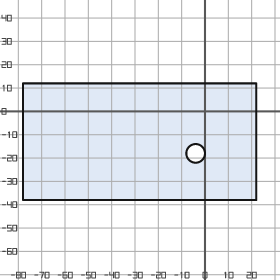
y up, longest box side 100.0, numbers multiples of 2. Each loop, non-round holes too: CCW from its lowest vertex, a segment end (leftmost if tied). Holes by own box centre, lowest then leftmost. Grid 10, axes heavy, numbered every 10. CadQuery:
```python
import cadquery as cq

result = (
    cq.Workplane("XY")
    .moveTo(-78.0, -38.0)
    .lineTo(22.0, -38.0)
    .lineTo(22.0, 12.0)
    .lineTo(-78.0, 12.0)
    .close()
    .moveTo(-4.0, -18.0)
    .circle(4.0)
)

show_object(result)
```